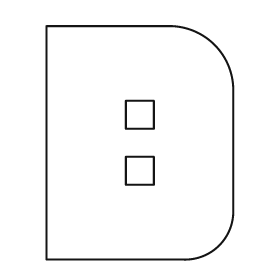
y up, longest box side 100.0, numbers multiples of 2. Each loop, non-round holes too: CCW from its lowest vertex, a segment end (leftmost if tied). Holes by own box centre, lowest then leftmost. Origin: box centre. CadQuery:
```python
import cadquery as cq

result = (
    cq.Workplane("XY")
    .moveTo(-40.0, -50.0)
    .lineTo(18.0, -50.0)
    .threePointArc((34.0, -44.0), (40.0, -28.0))
    .lineTo(40.0, 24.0)
    .threePointArc((32.0, 42.0), (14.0, 50.0))
    .lineTo(-40.0, 50.0)
    .close()
    .moveTo(-6.0, -18.0)
    .lineTo(6.0, -18.0)
    .lineTo(6.0, -6.0)
    .lineTo(-6.0, -6.0)
    .close()
    .moveTo(-6.0, 6.0)
    .lineTo(6.0, 6.0)
    .lineTo(6.0, 18.0)
    .lineTo(-6.0, 18.0)
    .close()
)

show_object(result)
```